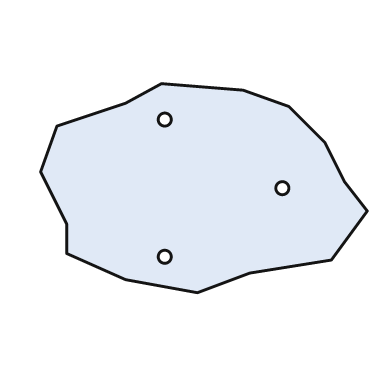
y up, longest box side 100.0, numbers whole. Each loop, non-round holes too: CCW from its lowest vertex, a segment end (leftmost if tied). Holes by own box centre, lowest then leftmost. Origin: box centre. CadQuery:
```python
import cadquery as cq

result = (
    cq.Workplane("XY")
    .moveTo(-2.0, -32.0)
    .lineTo(14.0, -26.0)
    .lineTo(39.0, -22.0)
    .lineTo(50.0, -7.0)
    .lineTo(43.0, 2.0)
    .lineTo(37.0, 14.0)
    .lineTo(26.0, 25.0)
    .lineTo(12.0, 30.0)
    .lineTo(-13.0, 32.0)
    .lineTo(-24.0, 26.0)
    .lineTo(-45.0, 19.0)
    .lineTo(-50.0, 5.0)
    .lineTo(-42.0, -11.0)
    .lineTo(-42.0, -20.0)
    .lineTo(-24.0, -28.0)
    .close()
    .moveTo(-12.0, -21.0)
    .circle(2.0)
    .moveTo(24.0, 0.0)
    .circle(2.0)
    .moveTo(-12.0, 21.0)
    .circle(2.0)
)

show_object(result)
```